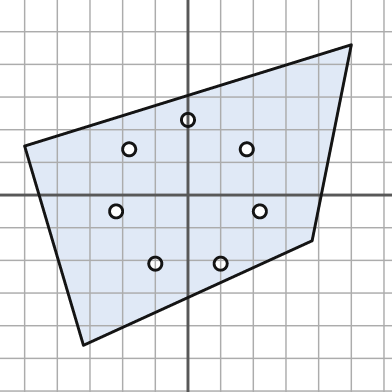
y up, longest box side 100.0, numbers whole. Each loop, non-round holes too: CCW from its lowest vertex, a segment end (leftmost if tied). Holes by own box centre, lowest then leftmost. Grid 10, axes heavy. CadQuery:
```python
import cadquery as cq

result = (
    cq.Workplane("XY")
    .moveTo(-32.0, -46.0)
    .lineTo(38.0, -14.0)
    .lineTo(50.0, 46.0)
    .lineTo(-50.0, 15.0)
    .close()
    .moveTo(-10.0, -21.0)
    .circle(2.0)
    .moveTo(10.0, -21.0)
    .circle(2.0)
    .moveTo(-22.0, -5.0)
    .circle(2.0)
    .moveTo(22.0, -5.0)
    .circle(2.0)
    .moveTo(-18.0, 14.0)
    .circle(2.0)
    .moveTo(18.0, 14.0)
    .circle(2.0)
    .moveTo(0.0, 23.0)
    .circle(2.0)
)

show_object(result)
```